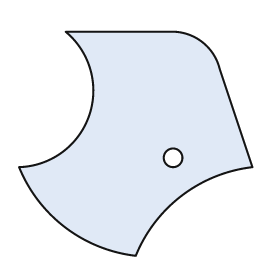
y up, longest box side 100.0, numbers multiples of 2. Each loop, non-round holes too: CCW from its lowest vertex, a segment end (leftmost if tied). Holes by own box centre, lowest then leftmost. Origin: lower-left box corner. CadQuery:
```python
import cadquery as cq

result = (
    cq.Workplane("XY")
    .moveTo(50.0, 0.0)
    .threePointArc((70.0, 26.0), (100.0, 38.0))
    .lineTo(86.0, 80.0)
    .threePointArc((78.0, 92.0), (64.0, 96.0))
    .lineTo(20.0, 96.0)
    .threePointArc((30.0, 60.0), (0.0, 38.0))
    .threePointArc((20.0, 12.0), (50.0, 0.0))
    .close()
    .moveTo(66.0, 42.0)
    .circle(4.0)
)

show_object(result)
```